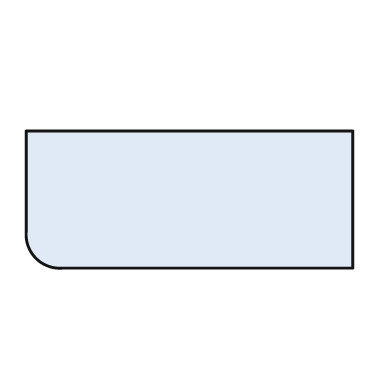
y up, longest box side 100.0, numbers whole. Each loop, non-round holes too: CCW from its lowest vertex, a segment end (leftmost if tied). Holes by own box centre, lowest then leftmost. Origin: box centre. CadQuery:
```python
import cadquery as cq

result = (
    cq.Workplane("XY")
    .moveTo(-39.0, -21.0)
    .lineTo(50.0, -21.0)
    .lineTo(50.0, 21.0)
    .lineTo(-50.0, 21.0)
    .lineTo(-50.0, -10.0)
    .threePointArc((-47.0, -18.0), (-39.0, -21.0))
    .close()
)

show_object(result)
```